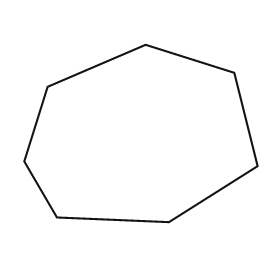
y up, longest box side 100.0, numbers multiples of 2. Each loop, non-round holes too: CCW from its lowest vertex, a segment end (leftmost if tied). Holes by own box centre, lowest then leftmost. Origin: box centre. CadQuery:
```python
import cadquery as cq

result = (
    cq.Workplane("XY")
    .moveTo(12.0, -38.0)
    .lineTo(50.0, -14.0)
    .lineTo(40.0, 26.0)
    .lineTo(2.0, 38.0)
    .lineTo(-40.0, 20.0)
    .lineTo(-50.0, -12.0)
    .lineTo(-36.0, -36.0)
    .close()
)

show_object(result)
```